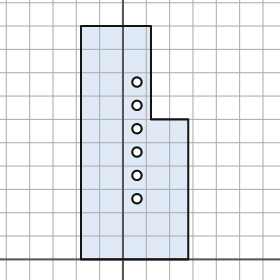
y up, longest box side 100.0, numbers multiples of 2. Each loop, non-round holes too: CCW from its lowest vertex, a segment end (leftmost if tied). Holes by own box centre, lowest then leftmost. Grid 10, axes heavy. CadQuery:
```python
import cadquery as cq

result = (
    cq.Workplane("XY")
    .moveTo(-18.0, 0.0)
    .lineTo(28.0, 0.0)
    .lineTo(28.0, 60.0)
    .lineTo(12.0, 60.0)
    .lineTo(12.0, 100.0)
    .lineTo(-18.0, 100.0)
    .close()
    .moveTo(6.0, 26.0)
    .circle(2.0)
    .moveTo(6.0, 36.0)
    .circle(2.0)
    .moveTo(6.0, 46.0)
    .circle(2.0)
    .moveTo(6.0, 56.0)
    .circle(2.0)
    .moveTo(6.0, 66.0)
    .circle(2.0)
    .moveTo(6.0, 76.0)
    .circle(2.0)
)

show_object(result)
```